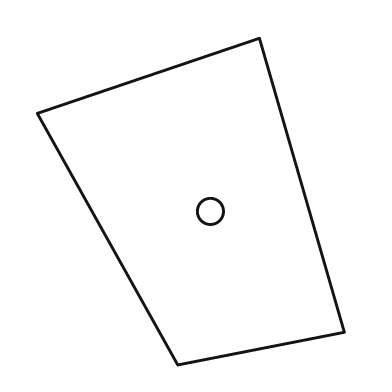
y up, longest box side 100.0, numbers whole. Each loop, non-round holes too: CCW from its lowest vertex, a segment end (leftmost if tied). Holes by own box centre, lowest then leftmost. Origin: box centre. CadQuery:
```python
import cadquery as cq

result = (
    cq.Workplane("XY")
    .moveTo(-4.0, -50.0)
    .lineTo(47.0, -40.0)
    .lineTo(21.0, 50.0)
    .lineTo(-47.0, 27.0)
    .close()
    .moveTo(6.0, -3.0)
    .circle(4.0)
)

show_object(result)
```